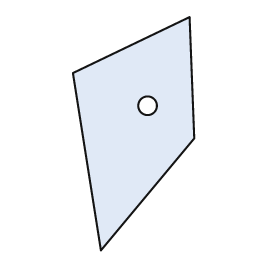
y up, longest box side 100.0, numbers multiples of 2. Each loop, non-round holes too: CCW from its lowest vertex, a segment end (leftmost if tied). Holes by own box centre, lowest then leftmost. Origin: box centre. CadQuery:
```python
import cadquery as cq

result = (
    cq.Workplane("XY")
    .moveTo(-14.0, -50.0)
    .lineTo(26.0, -2.0)
    .lineTo(24.0, 50.0)
    .lineTo(-26.0, 26.0)
    .close()
    .moveTo(6.0, 12.0)
    .circle(4.0)
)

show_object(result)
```